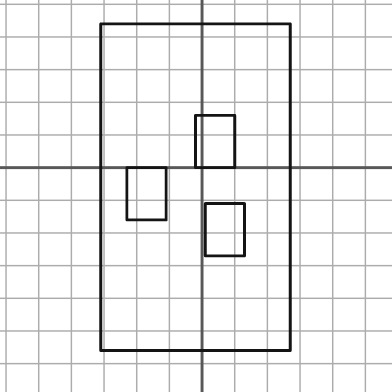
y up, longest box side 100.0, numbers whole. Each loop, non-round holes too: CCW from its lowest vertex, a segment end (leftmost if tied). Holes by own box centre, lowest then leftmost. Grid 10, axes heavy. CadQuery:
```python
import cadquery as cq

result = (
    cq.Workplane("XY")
    .moveTo(-31.0, -56.0)
    .lineTo(27.0, -56.0)
    .lineTo(27.0, 44.0)
    .lineTo(-31.0, 44.0)
    .close()
    .moveTo(1.0, -27.0)
    .lineTo(13.0, -27.0)
    .lineTo(13.0, -11.0)
    .lineTo(1.0, -11.0)
    .close()
    .moveTo(-23.0, -16.0)
    .lineTo(-11.0, -16.0)
    .lineTo(-11.0, 0.0)
    .lineTo(-23.0, 0.0)
    .close()
    .moveTo(-2.0, 0.0)
    .lineTo(10.0, 0.0)
    .lineTo(10.0, 16.0)
    .lineTo(-2.0, 16.0)
    .close()
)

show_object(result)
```